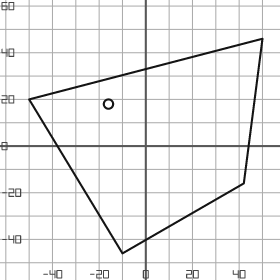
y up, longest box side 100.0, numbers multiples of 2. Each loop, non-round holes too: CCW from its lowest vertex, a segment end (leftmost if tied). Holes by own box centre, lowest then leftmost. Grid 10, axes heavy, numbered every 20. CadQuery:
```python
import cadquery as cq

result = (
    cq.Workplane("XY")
    .moveTo(-10.0, -46.0)
    .lineTo(42.0, -16.0)
    .lineTo(50.0, 46.0)
    .lineTo(-50.0, 20.0)
    .close()
    .moveTo(-16.0, 18.0)
    .circle(2.0)
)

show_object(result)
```